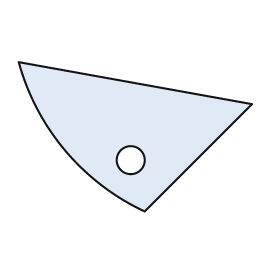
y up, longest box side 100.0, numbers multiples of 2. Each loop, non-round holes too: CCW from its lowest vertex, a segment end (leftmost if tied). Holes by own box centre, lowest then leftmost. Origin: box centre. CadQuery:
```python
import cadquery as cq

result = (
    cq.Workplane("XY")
    .moveTo(4.0, -32.0)
    .lineTo(50.0, 14.0)
    .lineTo(-50.0, 32.0)
    .threePointArc((-30.0, -6.0), (4.0, -32.0))
    .close()
    .moveTo(-2.0, -10.0)
    .circle(6.0)
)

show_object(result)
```